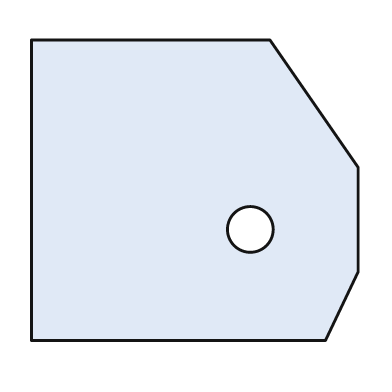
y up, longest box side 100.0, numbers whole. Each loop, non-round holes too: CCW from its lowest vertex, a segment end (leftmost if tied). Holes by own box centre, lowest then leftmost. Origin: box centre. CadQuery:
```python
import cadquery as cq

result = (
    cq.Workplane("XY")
    .moveTo(-50.0, -46.0)
    .lineTo(40.0, -46.0)
    .lineTo(50.0, -25.0)
    .lineTo(50.0, 7.0)
    .lineTo(23.0, 46.0)
    .lineTo(-50.0, 46.0)
    .close()
    .moveTo(17.0, -12.0)
    .circle(7.0)
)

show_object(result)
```